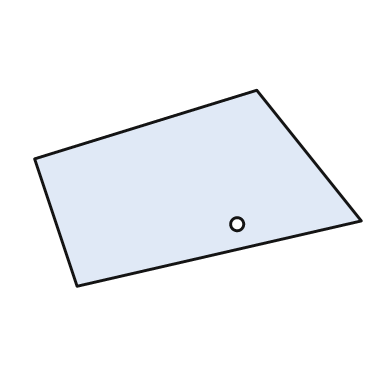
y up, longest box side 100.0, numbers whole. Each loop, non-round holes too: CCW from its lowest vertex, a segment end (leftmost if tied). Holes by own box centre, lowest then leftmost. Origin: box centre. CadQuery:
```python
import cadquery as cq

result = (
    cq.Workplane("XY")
    .moveTo(-37.0, -30.0)
    .lineTo(50.0, -10.0)
    .lineTo(18.0, 30.0)
    .lineTo(-50.0, 9.0)
    .close()
    .moveTo(12.0, -11.0)
    .circle(2.0)
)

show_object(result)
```